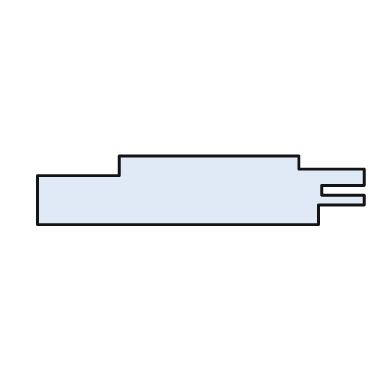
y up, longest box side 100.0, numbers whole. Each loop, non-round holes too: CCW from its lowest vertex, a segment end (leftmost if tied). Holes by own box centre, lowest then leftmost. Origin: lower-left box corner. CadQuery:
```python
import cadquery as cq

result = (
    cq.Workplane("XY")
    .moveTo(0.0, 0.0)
    .lineTo(86.0, 0.0)
    .lineTo(86.0, 6.0)
    .lineTo(100.0, 6.0)
    .lineTo(100.0, 9.0)
    .lineTo(87.0, 9.0)
    .lineTo(87.0, 12.0)
    .lineTo(100.0, 12.0)
    .lineTo(100.0, 17.0)
    .lineTo(80.0, 17.0)
    .lineTo(80.0, 21.0)
    .lineTo(25.0, 21.0)
    .lineTo(25.0, 15.0)
    .lineTo(0.0, 15.0)
    .close()
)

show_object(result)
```